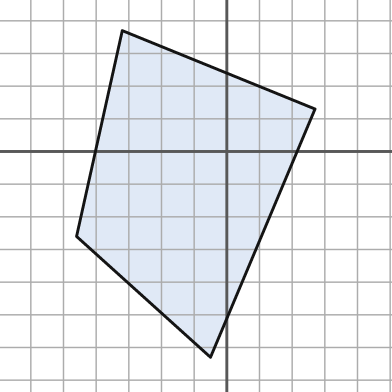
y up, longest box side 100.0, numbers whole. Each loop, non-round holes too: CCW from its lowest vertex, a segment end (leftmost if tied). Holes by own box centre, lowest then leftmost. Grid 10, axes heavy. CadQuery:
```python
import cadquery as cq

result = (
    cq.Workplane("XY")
    .moveTo(-5.0, -63.0)
    .lineTo(27.0, 13.0)
    .lineTo(-32.0, 37.0)
    .lineTo(-46.0, -26.0)
    .close()
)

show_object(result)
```